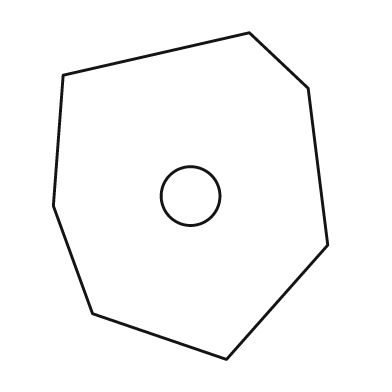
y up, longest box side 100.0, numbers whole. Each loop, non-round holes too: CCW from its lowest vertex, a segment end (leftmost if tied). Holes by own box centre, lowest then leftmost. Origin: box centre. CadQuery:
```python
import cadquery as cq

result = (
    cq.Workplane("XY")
    .moveTo(11.0, -50.0)
    .lineTo(42.0, -15.0)
    .lineTo(36.0, 33.0)
    .lineTo(18.0, 50.0)
    .lineTo(-39.0, 37.0)
    .lineTo(-42.0, -3.0)
    .lineTo(-30.0, -36.0)
    .close()
    .moveTo(0.0, 0.0)
    .circle(9.0)
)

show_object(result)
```